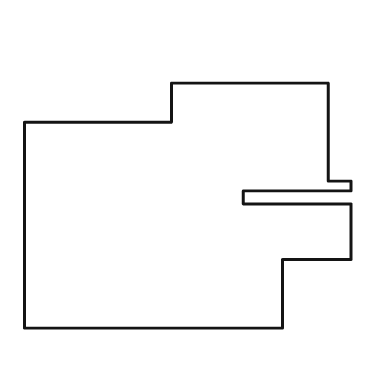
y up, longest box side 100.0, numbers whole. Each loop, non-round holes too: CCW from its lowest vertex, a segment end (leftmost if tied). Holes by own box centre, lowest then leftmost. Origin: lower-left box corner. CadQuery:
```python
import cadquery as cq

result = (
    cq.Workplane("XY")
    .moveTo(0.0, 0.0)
    .lineTo(79.0, 0.0)
    .lineTo(79.0, 21.0)
    .lineTo(100.0, 21.0)
    .lineTo(100.0, 38.0)
    .lineTo(67.0, 38.0)
    .lineTo(67.0, 42.0)
    .lineTo(100.0, 42.0)
    .lineTo(100.0, 45.0)
    .lineTo(93.0, 45.0)
    .lineTo(93.0, 75.0)
    .lineTo(45.0, 75.0)
    .lineTo(45.0, 63.0)
    .lineTo(0.0, 63.0)
    .close()
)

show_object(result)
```